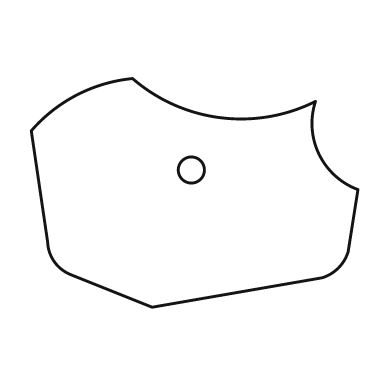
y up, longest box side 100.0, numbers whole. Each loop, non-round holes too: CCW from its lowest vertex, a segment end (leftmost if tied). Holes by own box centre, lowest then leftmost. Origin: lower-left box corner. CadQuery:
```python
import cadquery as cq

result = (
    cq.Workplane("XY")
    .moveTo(37.0, 0.0)
    .lineTo(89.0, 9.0)
    .threePointArc((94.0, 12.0), (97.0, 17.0))
    .lineTo(100.0, 36.0)
    .threePointArc((88.0, 47.0), (87.0, 63.0))
    .threePointArc((58.0, 58.0), (31.0, 70.0))
    .threePointArc((14.0, 65.0), (0.0, 54.0))
    .lineTo(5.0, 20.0)
    .threePointArc((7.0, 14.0), (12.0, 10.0))
    .close()
    .moveTo(49.0, 42.0)
    .circle(4.0)
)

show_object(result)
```